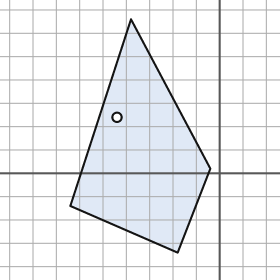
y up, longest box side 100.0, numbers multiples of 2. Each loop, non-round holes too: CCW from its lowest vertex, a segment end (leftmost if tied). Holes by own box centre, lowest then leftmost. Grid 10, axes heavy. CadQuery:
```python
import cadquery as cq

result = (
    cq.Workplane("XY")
    .moveTo(-18.0, -34.0)
    .lineTo(-4.0, 2.0)
    .lineTo(-38.0, 66.0)
    .lineTo(-64.0, -14.0)
    .close()
    .moveTo(-44.0, 24.0)
    .circle(2.0)
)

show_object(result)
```